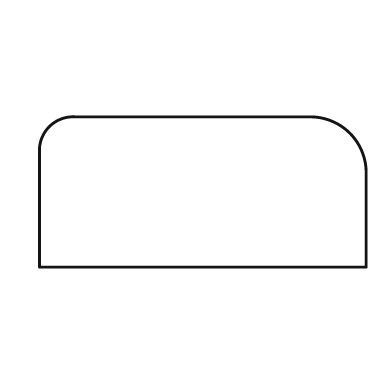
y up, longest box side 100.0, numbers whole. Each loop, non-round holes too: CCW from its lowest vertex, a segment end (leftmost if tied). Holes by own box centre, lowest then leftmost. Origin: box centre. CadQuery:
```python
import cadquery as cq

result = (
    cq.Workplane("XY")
    .moveTo(-50.0, -23.0)
    .lineTo(50.0, -23.0)
    .lineTo(50.0, 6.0)
    .threePointArc((45.0, 18.0), (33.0, 23.0))
    .lineTo(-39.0, 23.0)
    .threePointArc((-47.0, 20.0), (-50.0, 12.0))
    .close()
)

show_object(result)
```